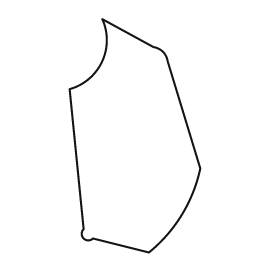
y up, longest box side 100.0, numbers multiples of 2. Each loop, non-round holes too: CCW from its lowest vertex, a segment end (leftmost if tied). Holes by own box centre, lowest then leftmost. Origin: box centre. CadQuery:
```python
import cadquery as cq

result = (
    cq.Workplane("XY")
    .moveTo(6.0, -50.0)
    .threePointArc((20.0, -34.0), (28.0, -14.0))
    .lineTo(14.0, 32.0)
    .threePointArc((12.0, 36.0), (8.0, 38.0))
    .lineTo(-14.0, 50.0)
    .threePointArc((-14.0, 32.0), (-28.0, 20.0))
    .lineTo(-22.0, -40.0)
    .threePointArc((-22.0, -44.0), (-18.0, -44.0))
    .close()
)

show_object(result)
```